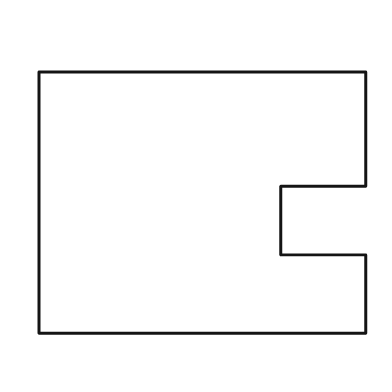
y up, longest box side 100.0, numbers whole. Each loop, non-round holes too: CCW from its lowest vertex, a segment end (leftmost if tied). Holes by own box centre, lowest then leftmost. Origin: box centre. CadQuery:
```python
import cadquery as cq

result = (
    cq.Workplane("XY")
    .moveTo(-50.0, -40.0)
    .lineTo(50.0, -40.0)
    .lineTo(50.0, -16.0)
    .lineTo(24.0, -16.0)
    .lineTo(24.0, 5.0)
    .lineTo(50.0, 5.0)
    .lineTo(50.0, 40.0)
    .lineTo(-50.0, 40.0)
    .close()
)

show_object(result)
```